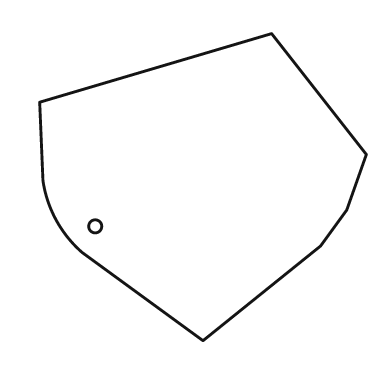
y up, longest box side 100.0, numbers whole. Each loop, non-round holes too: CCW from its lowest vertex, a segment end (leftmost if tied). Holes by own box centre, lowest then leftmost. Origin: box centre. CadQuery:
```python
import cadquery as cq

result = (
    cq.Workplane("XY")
    .moveTo(0.0, -47.0)
    .lineTo(36.0, -18.0)
    .lineTo(44.0, -7.0)
    .lineTo(50.0, 10.0)
    .lineTo(21.0, 47.0)
    .lineTo(-50.0, 26.0)
    .lineTo(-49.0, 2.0)
    .threePointArc((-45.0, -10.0), (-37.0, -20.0))
    .close()
    .moveTo(-33.0, -12.0)
    .circle(2.0)
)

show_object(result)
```